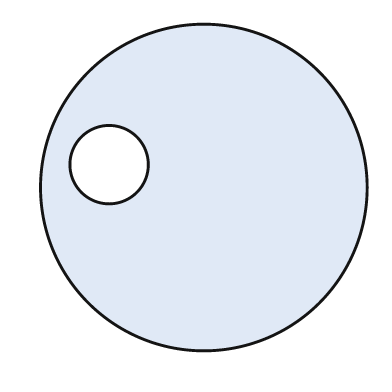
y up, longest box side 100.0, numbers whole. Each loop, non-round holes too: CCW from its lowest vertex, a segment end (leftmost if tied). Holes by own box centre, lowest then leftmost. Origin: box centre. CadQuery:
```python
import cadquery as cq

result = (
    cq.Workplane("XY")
    .moveTo(0.0, 0.0)
    .circle(50.0)
    .moveTo(-29.0, 7.0)
    .circle(12.0)
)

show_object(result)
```